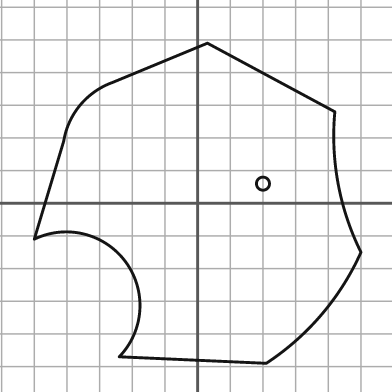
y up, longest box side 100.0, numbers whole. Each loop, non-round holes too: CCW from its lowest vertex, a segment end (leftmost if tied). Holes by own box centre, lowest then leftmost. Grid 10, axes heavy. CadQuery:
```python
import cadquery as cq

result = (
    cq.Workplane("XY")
    .moveTo(21.0, -49.0)
    .threePointArc((38.0, -34.0), (50.0, -15.0))
    .threePointArc((43.0, 6.0), (42.0, 28.0))
    .lineTo(3.0, 49.0)
    .lineTo(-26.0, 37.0)
    .threePointArc((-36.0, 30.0), (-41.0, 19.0))
    .lineTo(-50.0, -11.0)
    .threePointArc((-22.0, -18.0), (-24.0, -47.0))
    .close()
    .moveTo(20.0, 6.0)
    .circle(2.0)
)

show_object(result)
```